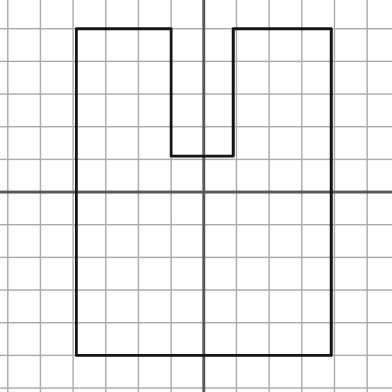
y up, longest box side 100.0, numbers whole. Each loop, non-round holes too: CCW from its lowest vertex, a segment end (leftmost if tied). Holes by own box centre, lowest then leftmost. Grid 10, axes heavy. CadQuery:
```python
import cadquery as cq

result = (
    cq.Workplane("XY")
    .moveTo(-39.0, -50.0)
    .lineTo(39.0, -50.0)
    .lineTo(39.0, 50.0)
    .lineTo(9.0, 50.0)
    .lineTo(9.0, 11.0)
    .lineTo(-10.0, 11.0)
    .lineTo(-10.0, 50.0)
    .lineTo(-39.0, 50.0)
    .close()
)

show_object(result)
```